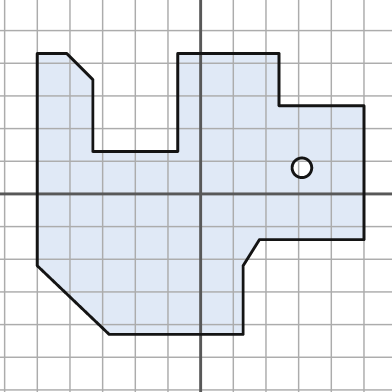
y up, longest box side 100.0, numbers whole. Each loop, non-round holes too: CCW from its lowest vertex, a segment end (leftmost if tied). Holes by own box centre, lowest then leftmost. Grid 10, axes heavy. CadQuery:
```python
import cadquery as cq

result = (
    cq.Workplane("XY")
    .moveTo(-28.0, -43.0)
    .lineTo(13.0, -43.0)
    .lineTo(13.0, -22.0)
    .lineTo(18.0, -14.0)
    .lineTo(50.0, -14.0)
    .lineTo(50.0, 27.0)
    .lineTo(24.0, 27.0)
    .lineTo(24.0, 43.0)
    .lineTo(-7.0, 43.0)
    .lineTo(-7.0, 13.0)
    .lineTo(-33.0, 13.0)
    .lineTo(-33.0, 35.0)
    .lineTo(-41.0, 43.0)
    .lineTo(-50.0, 43.0)
    .lineTo(-50.0, -22.0)
    .close()
    .moveTo(31.0, 8.0)
    .circle(3.0)
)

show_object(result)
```